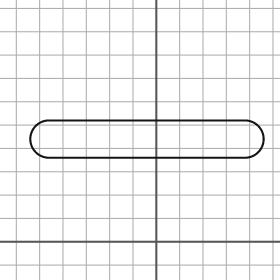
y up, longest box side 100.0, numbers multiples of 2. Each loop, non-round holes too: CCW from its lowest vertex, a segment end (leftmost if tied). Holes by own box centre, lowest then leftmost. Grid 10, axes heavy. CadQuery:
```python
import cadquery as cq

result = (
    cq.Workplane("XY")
    .moveTo(-46.0, 36.0)
    .lineTo(38.0, 36.0)
    .threePointArc((46.0, 44.0), (38.0, 52.0))
    .lineTo(-46.0, 52.0)
    .threePointArc((-54.0, 44.0), (-46.0, 36.0))
    .close()
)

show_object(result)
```